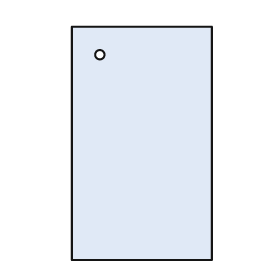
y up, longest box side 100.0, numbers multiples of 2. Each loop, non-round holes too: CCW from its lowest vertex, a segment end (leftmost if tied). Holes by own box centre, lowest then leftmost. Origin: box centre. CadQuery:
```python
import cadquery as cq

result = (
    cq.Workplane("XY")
    .moveTo(-30.0, -50.0)
    .lineTo(30.0, -50.0)
    .lineTo(30.0, 50.0)
    .lineTo(-30.0, 50.0)
    .close()
    .moveTo(-18.0, 38.0)
    .circle(2.0)
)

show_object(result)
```